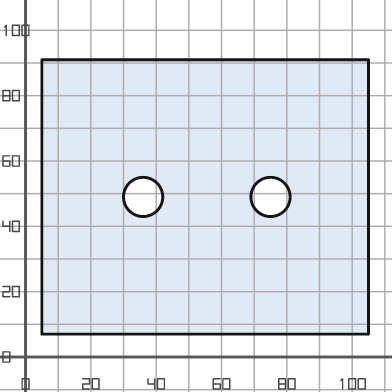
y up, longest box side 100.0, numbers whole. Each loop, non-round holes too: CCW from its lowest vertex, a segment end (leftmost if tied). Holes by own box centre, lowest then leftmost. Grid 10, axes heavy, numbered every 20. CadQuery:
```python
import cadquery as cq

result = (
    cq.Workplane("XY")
    .moveTo(5.0, 7.0)
    .lineTo(105.0, 7.0)
    .lineTo(105.0, 91.0)
    .lineTo(5.0, 91.0)
    .close()
    .moveTo(36.0, 49.0)
    .circle(6.0)
    .moveTo(75.0, 49.0)
    .circle(6.0)
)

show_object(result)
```